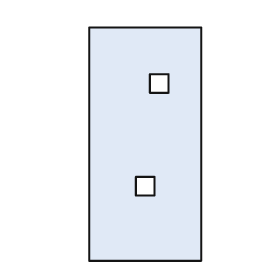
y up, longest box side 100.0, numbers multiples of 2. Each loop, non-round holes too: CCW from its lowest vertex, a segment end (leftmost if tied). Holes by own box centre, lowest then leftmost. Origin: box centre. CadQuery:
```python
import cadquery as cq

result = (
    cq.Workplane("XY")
    .moveTo(-24.0, -50.0)
    .lineTo(24.0, -50.0)
    .lineTo(24.0, 50.0)
    .lineTo(-24.0, 50.0)
    .close()
    .moveTo(-4.0, -22.0)
    .lineTo(4.0, -22.0)
    .lineTo(4.0, -14.0)
    .lineTo(-4.0, -14.0)
    .close()
    .moveTo(2.0, 22.0)
    .lineTo(10.0, 22.0)
    .lineTo(10.0, 30.0)
    .lineTo(2.0, 30.0)
    .close()
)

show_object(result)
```